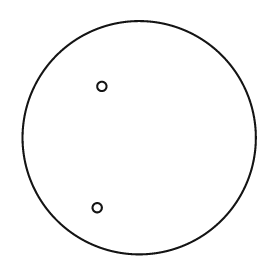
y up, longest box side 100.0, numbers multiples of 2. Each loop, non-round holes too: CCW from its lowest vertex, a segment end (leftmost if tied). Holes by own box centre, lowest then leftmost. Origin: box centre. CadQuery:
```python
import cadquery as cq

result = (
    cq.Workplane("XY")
    .moveTo(0.0, 0.0)
    .circle(50.0)
    .moveTo(-18.0, -30.0)
    .circle(2.0)
    .moveTo(-16.0, 22.0)
    .circle(2.0)
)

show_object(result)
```